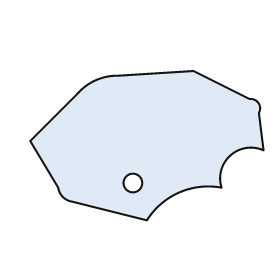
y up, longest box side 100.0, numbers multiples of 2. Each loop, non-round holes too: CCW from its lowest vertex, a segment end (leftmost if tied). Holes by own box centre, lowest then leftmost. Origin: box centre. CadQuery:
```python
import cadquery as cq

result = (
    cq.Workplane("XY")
    .moveTo(0.0, -32.0)
    .threePointArc((14.0, -20.0), (32.0, -18.0))
    .threePointArc((36.0, -4.0), (50.0, -2.0))
    .lineTo(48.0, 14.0)
    .threePointArc((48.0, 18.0), (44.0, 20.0))
    .lineTo(20.0, 32.0)
    .lineTo(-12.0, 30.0)
    .threePointArc((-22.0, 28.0), (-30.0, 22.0))
    .lineTo(-50.0, 2.0)
    .lineTo(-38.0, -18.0)
    .threePointArc((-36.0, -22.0), (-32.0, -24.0))
    .close()
    .moveTo(-6.0, -16.0)
    .circle(4.0)
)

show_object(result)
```